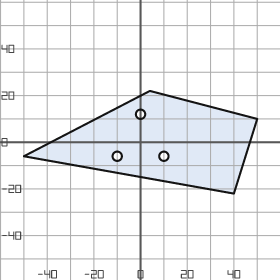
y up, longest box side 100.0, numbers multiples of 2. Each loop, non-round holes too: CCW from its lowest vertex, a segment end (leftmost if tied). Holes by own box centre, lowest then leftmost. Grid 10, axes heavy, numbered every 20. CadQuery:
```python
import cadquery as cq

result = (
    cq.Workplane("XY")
    .moveTo(40.0, -22.0)
    .lineTo(50.0, 10.0)
    .lineTo(4.0, 22.0)
    .lineTo(-50.0, -6.0)
    .close()
    .moveTo(-10.0, -6.0)
    .circle(2.0)
    .moveTo(10.0, -6.0)
    .circle(2.0)
    .moveTo(0.0, 12.0)
    .circle(2.0)
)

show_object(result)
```